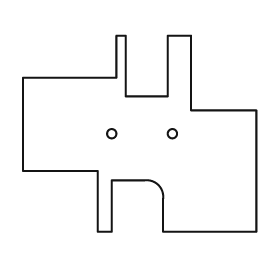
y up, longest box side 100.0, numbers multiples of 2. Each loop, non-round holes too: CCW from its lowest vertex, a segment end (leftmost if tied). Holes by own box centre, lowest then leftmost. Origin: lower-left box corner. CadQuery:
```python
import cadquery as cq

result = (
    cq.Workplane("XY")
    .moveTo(32.0, 0.0)
    .lineTo(38.0, 0.0)
    .lineTo(38.0, 22.0)
    .lineTo(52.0, 22.0)
    .threePointArc((58.0, 20.0), (60.0, 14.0))
    .lineTo(60.0, 0.0)
    .lineTo(100.0, 0.0)
    .lineTo(100.0, 52.0)
    .lineTo(72.0, 52.0)
    .lineTo(72.0, 84.0)
    .lineTo(62.0, 84.0)
    .lineTo(62.0, 58.0)
    .lineTo(44.0, 58.0)
    .lineTo(44.0, 84.0)
    .lineTo(40.0, 84.0)
    .lineTo(40.0, 66.0)
    .lineTo(0.0, 66.0)
    .lineTo(0.0, 26.0)
    .lineTo(32.0, 26.0)
    .close()
    .moveTo(38.0, 42.0)
    .circle(2.0)
    .moveTo(64.0, 42.0)
    .circle(2.0)
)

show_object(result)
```